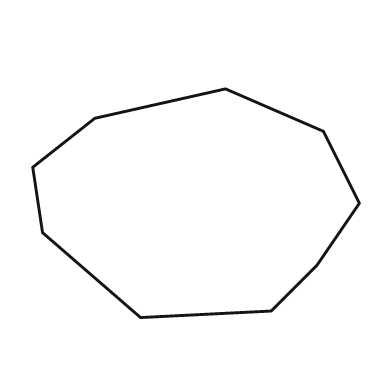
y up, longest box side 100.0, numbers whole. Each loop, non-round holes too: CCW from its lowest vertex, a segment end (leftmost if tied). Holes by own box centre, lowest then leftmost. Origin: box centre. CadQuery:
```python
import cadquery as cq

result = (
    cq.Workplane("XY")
    .moveTo(-17.0, -35.0)
    .lineTo(23.0, -33.0)
    .lineTo(37.0, -19.0)
    .lineTo(50.0, 0.0)
    .lineTo(39.0, 22.0)
    .lineTo(9.0, 35.0)
    .lineTo(-31.0, 26.0)
    .lineTo(-50.0, 11.0)
    .lineTo(-47.0, -9.0)
    .close()
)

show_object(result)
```